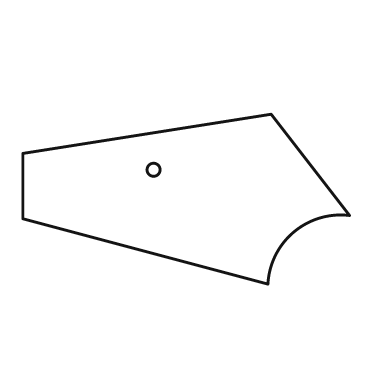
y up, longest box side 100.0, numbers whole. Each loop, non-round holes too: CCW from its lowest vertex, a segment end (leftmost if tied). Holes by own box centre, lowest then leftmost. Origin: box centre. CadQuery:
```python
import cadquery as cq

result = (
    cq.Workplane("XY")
    .moveTo(25.0, -26.0)
    .threePointArc((33.0, -10.0), (50.0, -5.0))
    .lineTo(26.0, 26.0)
    .lineTo(-50.0, 14.0)
    .lineTo(-50.0, -6.0)
    .close()
    .moveTo(-10.0, 9.0)
    .circle(2.0)
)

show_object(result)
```